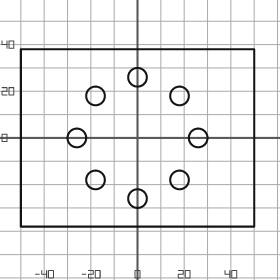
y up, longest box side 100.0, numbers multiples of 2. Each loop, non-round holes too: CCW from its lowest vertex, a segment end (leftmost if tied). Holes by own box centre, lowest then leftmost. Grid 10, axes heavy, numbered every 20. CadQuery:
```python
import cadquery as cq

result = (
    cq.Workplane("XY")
    .moveTo(-50.0, -38.0)
    .lineTo(50.0, -38.0)
    .lineTo(50.0, 38.0)
    .lineTo(-50.0, 38.0)
    .close()
    .moveTo(0.0, -26.0)
    .circle(4.0)
    .moveTo(-18.0, -18.0)
    .circle(4.0)
    .moveTo(18.0, -18.0)
    .circle(4.0)
    .moveTo(-26.0, 0.0)
    .circle(4.0)
    .moveTo(26.0, 0.0)
    .circle(4.0)
    .moveTo(-18.0, 18.0)
    .circle(4.0)
    .moveTo(18.0, 18.0)
    .circle(4.0)
    .moveTo(0.0, 26.0)
    .circle(4.0)
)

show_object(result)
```